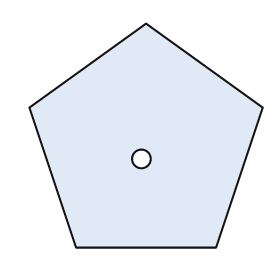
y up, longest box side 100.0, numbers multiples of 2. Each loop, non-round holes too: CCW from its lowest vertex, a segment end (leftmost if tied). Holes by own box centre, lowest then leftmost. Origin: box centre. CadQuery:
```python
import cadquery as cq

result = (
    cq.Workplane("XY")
    .moveTo(-30.0, -48.0)
    .lineTo(30.0, -48.0)
    .lineTo(50.0, 12.0)
    .lineTo(0.0, 48.0)
    .lineTo(-50.0, 12.0)
    .close()
    .moveTo(-2.0, -10.0)
    .circle(4.0)
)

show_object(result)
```